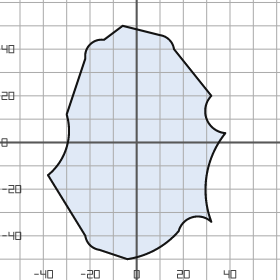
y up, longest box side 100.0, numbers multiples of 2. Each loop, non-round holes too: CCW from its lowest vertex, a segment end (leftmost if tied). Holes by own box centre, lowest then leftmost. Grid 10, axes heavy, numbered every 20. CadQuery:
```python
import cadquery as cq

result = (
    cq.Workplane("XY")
    .moveTo(-4.0, -50.0)
    .threePointArc((8.0, -46.0), (18.0, -38.0))
    .threePointArc((24.0, -32.0), (32.0, -34.0))
    .threePointArc((30.0, -14.0), (38.0, 4.0))
    .threePointArc((30.0, 10.0), (32.0, 20.0))
    .lineTo(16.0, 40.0)
    .threePointArc((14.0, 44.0), (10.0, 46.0))
    .lineTo(-6.0, 50.0)
    .lineTo(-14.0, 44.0)
    .threePointArc((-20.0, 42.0), (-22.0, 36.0))
    .lineTo(-30.0, 12.0)
    .threePointArc((-30.0, -2.0), (-38.0, -14.0))
    .lineTo(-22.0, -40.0)
    .threePointArc((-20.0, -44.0), (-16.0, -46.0))
    .close()
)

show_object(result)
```